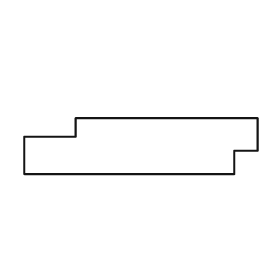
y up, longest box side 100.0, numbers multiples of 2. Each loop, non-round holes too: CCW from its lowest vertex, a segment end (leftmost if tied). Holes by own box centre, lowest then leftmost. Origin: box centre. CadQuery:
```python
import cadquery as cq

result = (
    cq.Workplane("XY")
    .moveTo(-50.0, -12.0)
    .lineTo(40.0, -12.0)
    .lineTo(40.0, -2.0)
    .lineTo(50.0, -2.0)
    .lineTo(50.0, 12.0)
    .lineTo(-28.0, 12.0)
    .lineTo(-28.0, 4.0)
    .lineTo(-50.0, 4.0)
    .close()
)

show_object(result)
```